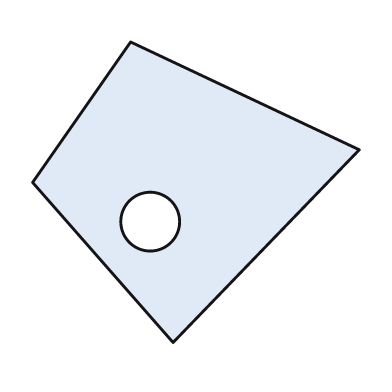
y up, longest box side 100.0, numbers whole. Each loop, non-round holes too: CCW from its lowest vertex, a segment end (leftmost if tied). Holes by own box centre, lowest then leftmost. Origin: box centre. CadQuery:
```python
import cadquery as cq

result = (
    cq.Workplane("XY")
    .moveTo(-7.0, -46.0)
    .lineTo(50.0, 13.0)
    .lineTo(-20.0, 46.0)
    .lineTo(-50.0, 3.0)
    .close()
    .moveTo(-14.0, -9.0)
    .circle(9.0)
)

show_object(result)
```